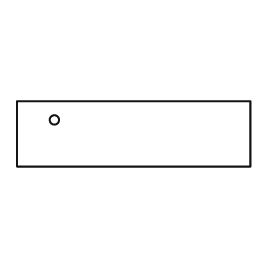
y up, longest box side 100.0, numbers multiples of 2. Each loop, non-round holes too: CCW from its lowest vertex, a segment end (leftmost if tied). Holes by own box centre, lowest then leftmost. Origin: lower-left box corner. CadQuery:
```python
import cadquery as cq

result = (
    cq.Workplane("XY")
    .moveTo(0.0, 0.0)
    .lineTo(100.0, 0.0)
    .lineTo(100.0, 28.0)
    .lineTo(0.0, 28.0)
    .close()
    .moveTo(16.0, 20.0)
    .circle(2.0)
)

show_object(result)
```